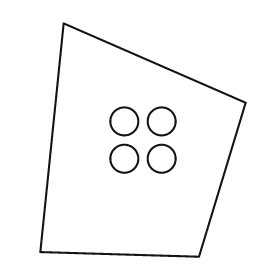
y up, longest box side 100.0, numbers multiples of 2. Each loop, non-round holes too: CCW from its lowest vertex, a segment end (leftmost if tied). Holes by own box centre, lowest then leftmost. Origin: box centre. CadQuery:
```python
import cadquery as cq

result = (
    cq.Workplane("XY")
    .moveTo(24.0, -50.0)
    .lineTo(44.0, 16.0)
    .lineTo(-34.0, 50.0)
    .lineTo(-44.0, -48.0)
    .close()
    .moveTo(-8.0, -8.0)
    .circle(6.0)
    .moveTo(8.0, -8.0)
    .circle(6.0)
    .moveTo(-8.0, 8.0)
    .circle(6.0)
    .moveTo(8.0, 8.0)
    .circle(6.0)
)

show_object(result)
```